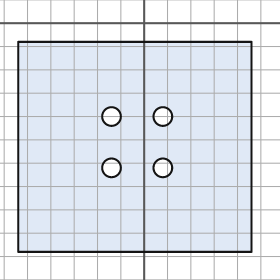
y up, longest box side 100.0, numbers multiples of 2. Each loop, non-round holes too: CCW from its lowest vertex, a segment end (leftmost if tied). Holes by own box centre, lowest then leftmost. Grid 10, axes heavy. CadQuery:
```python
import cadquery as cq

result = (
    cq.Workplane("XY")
    .moveTo(-54.0, -98.0)
    .lineTo(46.0, -98.0)
    .lineTo(46.0, -8.0)
    .lineTo(-54.0, -8.0)
    .close()
    .moveTo(-14.0, -62.0)
    .circle(4.0)
    .moveTo(8.0, -62.0)
    .circle(4.0)
    .moveTo(-14.0, -40.0)
    .circle(4.0)
    .moveTo(8.0, -40.0)
    .circle(4.0)
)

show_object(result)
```